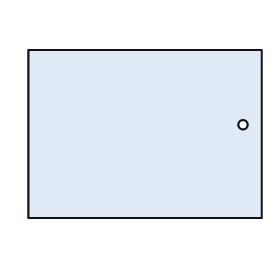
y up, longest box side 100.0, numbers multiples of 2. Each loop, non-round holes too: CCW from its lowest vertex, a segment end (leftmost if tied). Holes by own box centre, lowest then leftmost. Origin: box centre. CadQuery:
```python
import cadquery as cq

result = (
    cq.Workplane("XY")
    .moveTo(-50.0, -36.0)
    .lineTo(50.0, -36.0)
    .lineTo(50.0, 36.0)
    .lineTo(-50.0, 36.0)
    .close()
    .moveTo(42.0, 4.0)
    .circle(2.0)
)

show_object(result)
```